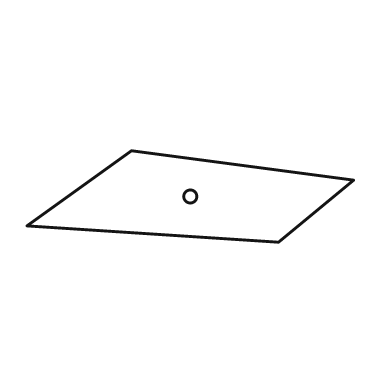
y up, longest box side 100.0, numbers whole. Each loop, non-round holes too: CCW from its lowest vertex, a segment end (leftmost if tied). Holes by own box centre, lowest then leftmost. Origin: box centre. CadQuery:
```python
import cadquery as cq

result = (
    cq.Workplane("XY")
    .moveTo(27.0, -14.0)
    .lineTo(50.0, 5.0)
    .lineTo(-18.0, 14.0)
    .lineTo(-50.0, -9.0)
    .close()
    .moveTo(0.0, 0.0)
    .circle(2.0)
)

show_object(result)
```